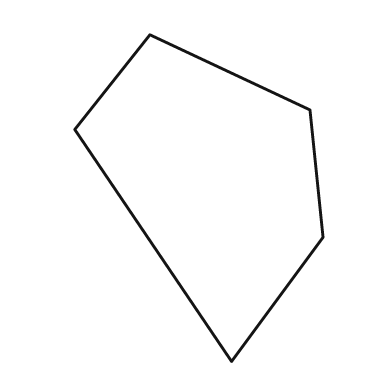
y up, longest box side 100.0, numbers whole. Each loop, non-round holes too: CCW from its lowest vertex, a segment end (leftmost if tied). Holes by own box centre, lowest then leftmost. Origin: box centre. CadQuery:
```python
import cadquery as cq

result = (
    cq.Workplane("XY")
    .moveTo(10.0, -50.0)
    .lineTo(38.0, -12.0)
    .lineTo(34.0, 27.0)
    .lineTo(-15.0, 50.0)
    .lineTo(-38.0, 21.0)
    .close()
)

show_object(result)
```